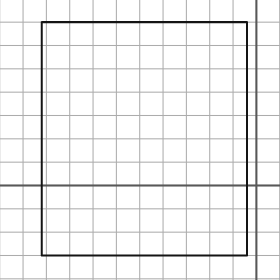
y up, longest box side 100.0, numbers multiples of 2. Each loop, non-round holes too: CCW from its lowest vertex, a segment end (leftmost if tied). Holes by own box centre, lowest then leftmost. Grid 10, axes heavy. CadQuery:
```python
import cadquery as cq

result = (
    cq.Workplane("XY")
    .moveTo(-92.0, -30.0)
    .lineTo(-4.0, -30.0)
    .lineTo(-4.0, 70.0)
    .lineTo(-92.0, 70.0)
    .close()
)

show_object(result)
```